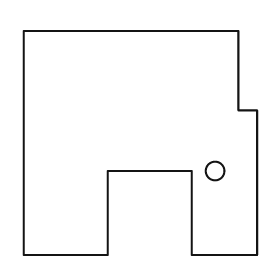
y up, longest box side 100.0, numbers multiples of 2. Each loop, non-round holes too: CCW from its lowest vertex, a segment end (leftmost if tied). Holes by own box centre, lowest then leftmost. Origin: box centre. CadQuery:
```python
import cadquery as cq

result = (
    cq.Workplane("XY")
    .moveTo(-50.0, -48.0)
    .lineTo(-14.0, -48.0)
    .lineTo(-14.0, -12.0)
    .lineTo(22.0, -12.0)
    .lineTo(22.0, -48.0)
    .lineTo(50.0, -48.0)
    .lineTo(50.0, 14.0)
    .lineTo(42.0, 14.0)
    .lineTo(42.0, 48.0)
    .lineTo(-50.0, 48.0)
    .close()
    .moveTo(32.0, -12.0)
    .circle(4.0)
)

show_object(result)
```